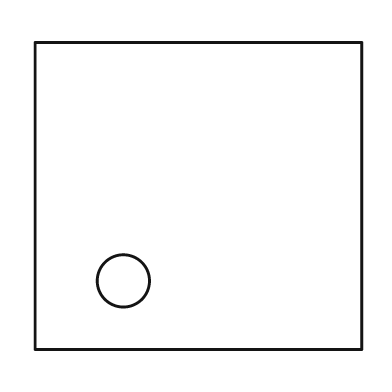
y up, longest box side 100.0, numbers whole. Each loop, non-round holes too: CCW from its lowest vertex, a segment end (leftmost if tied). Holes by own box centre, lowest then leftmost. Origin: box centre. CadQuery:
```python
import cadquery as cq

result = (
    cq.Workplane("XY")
    .moveTo(-50.0, -47.0)
    .lineTo(50.0, -47.0)
    .lineTo(50.0, 47.0)
    .lineTo(-50.0, 47.0)
    .close()
    .moveTo(-23.0, -26.0)
    .circle(8.0)
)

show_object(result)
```